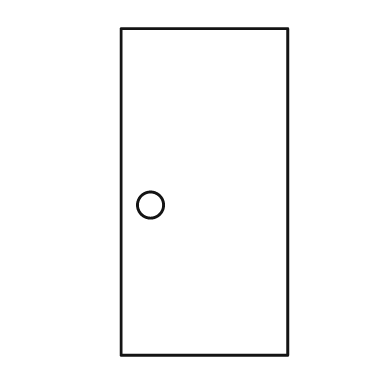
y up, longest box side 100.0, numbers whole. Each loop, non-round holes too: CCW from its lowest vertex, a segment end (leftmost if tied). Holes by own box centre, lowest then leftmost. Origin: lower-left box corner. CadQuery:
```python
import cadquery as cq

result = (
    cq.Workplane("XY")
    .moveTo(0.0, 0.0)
    .lineTo(51.0, 0.0)
    .lineTo(51.0, 100.0)
    .lineTo(0.0, 100.0)
    .close()
    .moveTo(9.0, 46.0)
    .circle(4.0)
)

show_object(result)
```